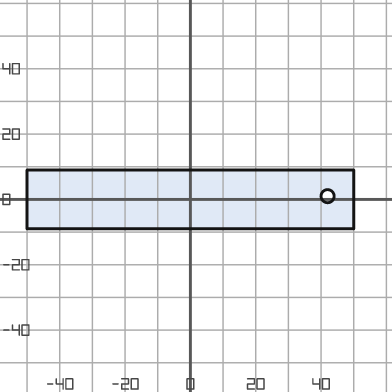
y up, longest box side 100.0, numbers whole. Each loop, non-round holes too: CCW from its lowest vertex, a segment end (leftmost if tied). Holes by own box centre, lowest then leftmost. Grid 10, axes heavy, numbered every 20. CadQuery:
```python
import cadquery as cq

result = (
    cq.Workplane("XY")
    .moveTo(-50.0, -9.0)
    .lineTo(50.0, -9.0)
    .lineTo(50.0, 9.0)
    .lineTo(-50.0, 9.0)
    .close()
    .moveTo(42.0, 1.0)
    .circle(2.0)
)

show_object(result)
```